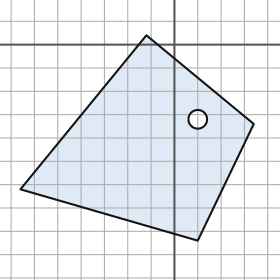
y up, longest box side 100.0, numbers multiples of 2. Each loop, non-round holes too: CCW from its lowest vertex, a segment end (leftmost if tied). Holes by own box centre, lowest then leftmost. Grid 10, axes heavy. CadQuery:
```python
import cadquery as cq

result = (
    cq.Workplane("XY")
    .moveTo(10.0, -84.0)
    .lineTo(34.0, -34.0)
    .lineTo(-12.0, 4.0)
    .lineTo(-66.0, -62.0)
    .close()
    .moveTo(10.0, -32.0)
    .circle(4.0)
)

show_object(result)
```